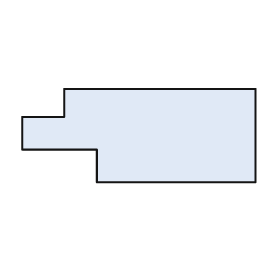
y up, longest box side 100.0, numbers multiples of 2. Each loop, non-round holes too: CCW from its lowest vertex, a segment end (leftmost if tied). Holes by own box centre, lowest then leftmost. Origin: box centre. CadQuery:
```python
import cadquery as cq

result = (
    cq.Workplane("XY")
    .moveTo(-18.0, -20.0)
    .lineTo(50.0, -20.0)
    .lineTo(50.0, 20.0)
    .lineTo(-32.0, 20.0)
    .lineTo(-32.0, 8.0)
    .lineTo(-50.0, 8.0)
    .lineTo(-50.0, -6.0)
    .lineTo(-18.0, -6.0)
    .close()
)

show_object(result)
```